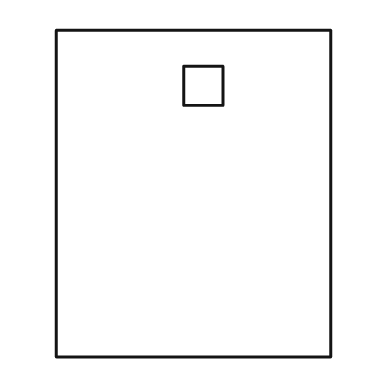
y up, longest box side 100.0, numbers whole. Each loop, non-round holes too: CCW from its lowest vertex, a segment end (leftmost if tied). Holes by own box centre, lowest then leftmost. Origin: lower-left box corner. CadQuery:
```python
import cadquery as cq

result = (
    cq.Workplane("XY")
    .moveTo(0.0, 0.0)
    .lineTo(84.0, 0.0)
    .lineTo(84.0, 100.0)
    .lineTo(0.0, 100.0)
    .close()
    .moveTo(39.0, 77.0)
    .lineTo(51.0, 77.0)
    .lineTo(51.0, 89.0)
    .lineTo(39.0, 89.0)
    .close()
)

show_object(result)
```